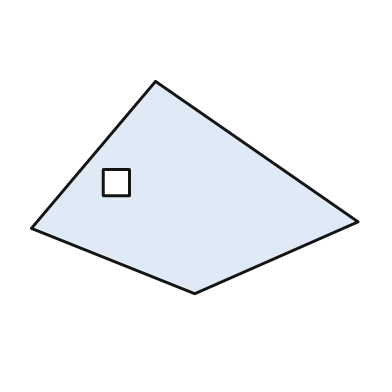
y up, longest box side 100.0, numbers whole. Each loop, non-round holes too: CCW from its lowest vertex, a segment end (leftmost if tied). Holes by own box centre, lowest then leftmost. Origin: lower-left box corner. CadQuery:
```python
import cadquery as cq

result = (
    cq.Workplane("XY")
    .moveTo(50.0, 0.0)
    .lineTo(100.0, 22.0)
    .lineTo(38.0, 65.0)
    .lineTo(0.0, 20.0)
    .close()
    .moveTo(22.0, 30.0)
    .lineTo(30.0, 30.0)
    .lineTo(30.0, 38.0)
    .lineTo(22.0, 38.0)
    .close()
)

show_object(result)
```